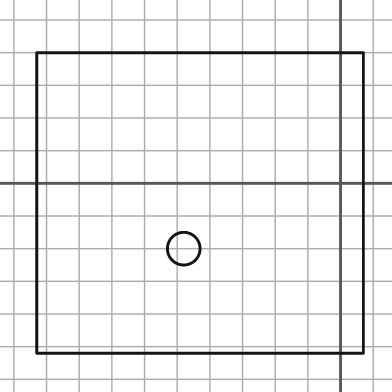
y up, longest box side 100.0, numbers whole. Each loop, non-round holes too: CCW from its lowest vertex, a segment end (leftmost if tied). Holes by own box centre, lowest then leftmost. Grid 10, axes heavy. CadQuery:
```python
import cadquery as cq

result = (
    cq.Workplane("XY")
    .moveTo(-93.0, -52.0)
    .lineTo(7.0, -52.0)
    .lineTo(7.0, 40.0)
    .lineTo(-93.0, 40.0)
    .close()
    .moveTo(-48.0, -20.0)
    .circle(5.0)
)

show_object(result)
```